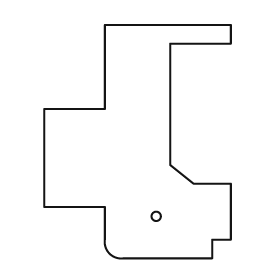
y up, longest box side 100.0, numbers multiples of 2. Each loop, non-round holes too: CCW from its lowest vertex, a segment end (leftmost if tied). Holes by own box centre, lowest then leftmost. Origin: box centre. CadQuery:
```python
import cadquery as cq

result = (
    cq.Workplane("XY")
    .moveTo(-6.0, -50.0)
    .lineTo(32.0, -50.0)
    .lineTo(32.0, -42.0)
    .lineTo(40.0, -42.0)
    .lineTo(40.0, -18.0)
    .lineTo(24.0, -18.0)
    .lineTo(14.0, -10.0)
    .lineTo(14.0, 42.0)
    .lineTo(40.0, 42.0)
    .lineTo(40.0, 50.0)
    .lineTo(-14.0, 50.0)
    .lineTo(-14.0, 14.0)
    .lineTo(-40.0, 14.0)
    .lineTo(-40.0, -28.0)
    .lineTo(-14.0, -28.0)
    .lineTo(-14.0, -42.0)
    .threePointArc((-12.0, -48.0), (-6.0, -50.0))
    .close()
    .moveTo(8.0, -32.0)
    .circle(2.0)
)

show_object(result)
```